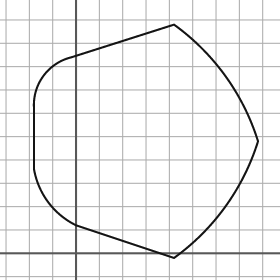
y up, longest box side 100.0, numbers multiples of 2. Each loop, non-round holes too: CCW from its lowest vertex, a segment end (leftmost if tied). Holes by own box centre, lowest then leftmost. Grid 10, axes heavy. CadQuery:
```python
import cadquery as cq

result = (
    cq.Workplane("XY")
    .moveTo(42.0, -2.0)
    .threePointArc((64.0, 20.0), (78.0, 48.0))
    .threePointArc((64.0, 76.0), (42.0, 98.0))
    .lineTo(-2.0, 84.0)
    .threePointArc((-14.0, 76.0), (-18.0, 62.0))
    .lineTo(-18.0, 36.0)
    .threePointArc((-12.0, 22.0), (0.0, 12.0))
    .close()
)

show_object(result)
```